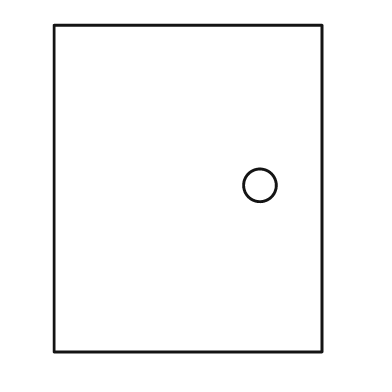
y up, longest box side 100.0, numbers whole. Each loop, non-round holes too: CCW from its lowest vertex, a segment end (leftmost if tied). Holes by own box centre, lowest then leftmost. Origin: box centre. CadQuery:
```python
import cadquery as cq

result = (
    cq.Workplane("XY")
    .moveTo(-41.0, -50.0)
    .lineTo(41.0, -50.0)
    .lineTo(41.0, 50.0)
    .lineTo(-41.0, 50.0)
    .close()
    .moveTo(22.0, 1.0)
    .circle(5.0)
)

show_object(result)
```